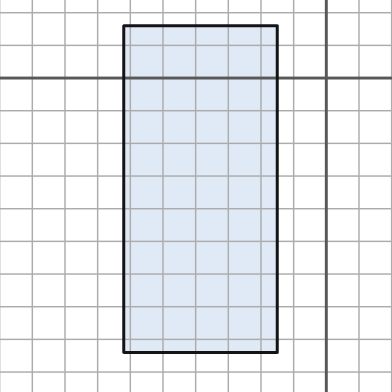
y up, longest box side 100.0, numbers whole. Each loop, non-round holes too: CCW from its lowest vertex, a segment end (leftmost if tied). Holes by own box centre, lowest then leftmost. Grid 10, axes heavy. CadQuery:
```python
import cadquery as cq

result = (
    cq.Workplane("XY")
    .moveTo(-62.0, -84.0)
    .lineTo(-15.0, -84.0)
    .lineTo(-15.0, 16.0)
    .lineTo(-62.0, 16.0)
    .close()
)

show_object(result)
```